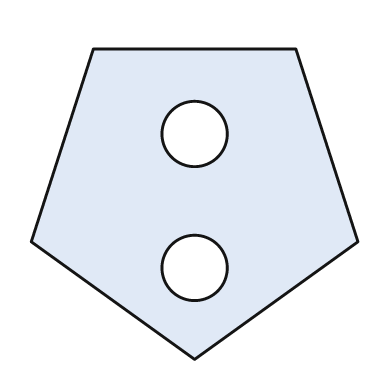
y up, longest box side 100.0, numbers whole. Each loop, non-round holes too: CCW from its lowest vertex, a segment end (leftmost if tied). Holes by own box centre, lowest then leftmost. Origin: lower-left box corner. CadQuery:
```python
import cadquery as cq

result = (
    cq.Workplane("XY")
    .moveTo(50.0, 0.0)
    .lineTo(100.0, 36.0)
    .lineTo(81.0, 95.0)
    .lineTo(19.0, 95.0)
    .lineTo(0.0, 36.0)
    .close()
    .moveTo(50.0, 28.0)
    .circle(10.0)
    .moveTo(50.0, 69.0)
    .circle(10.0)
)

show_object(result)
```